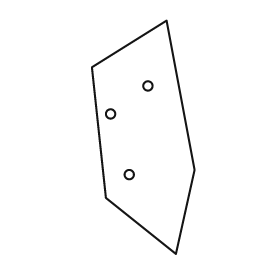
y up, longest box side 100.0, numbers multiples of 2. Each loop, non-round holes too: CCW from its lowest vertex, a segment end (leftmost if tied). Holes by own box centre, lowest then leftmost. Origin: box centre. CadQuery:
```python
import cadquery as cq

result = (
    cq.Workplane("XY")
    .moveTo(14.0, -50.0)
    .lineTo(22.0, -14.0)
    .lineTo(10.0, 50.0)
    .lineTo(-22.0, 30.0)
    .lineTo(-16.0, -26.0)
    .close()
    .moveTo(-6.0, -16.0)
    .circle(2.0)
    .moveTo(-14.0, 10.0)
    .circle(2.0)
    .moveTo(2.0, 22.0)
    .circle(2.0)
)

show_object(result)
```